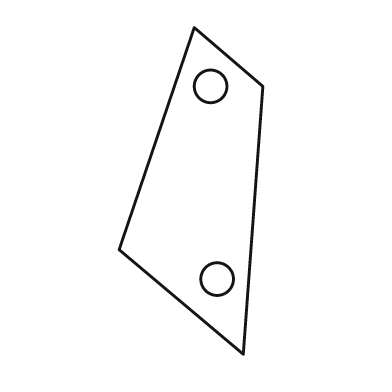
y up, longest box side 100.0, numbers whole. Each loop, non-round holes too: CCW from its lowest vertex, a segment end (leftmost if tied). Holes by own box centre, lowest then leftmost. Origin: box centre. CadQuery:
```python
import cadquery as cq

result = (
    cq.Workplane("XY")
    .moveTo(16.0, -50.0)
    .lineTo(22.0, 32.0)
    .lineTo(1.0, 50.0)
    .lineTo(-22.0, -18.0)
    .close()
    .moveTo(8.0, -27.0)
    .circle(5.0)
    .moveTo(6.0, 32.0)
    .circle(5.0)
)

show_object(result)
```